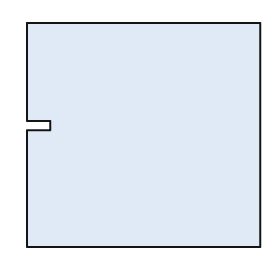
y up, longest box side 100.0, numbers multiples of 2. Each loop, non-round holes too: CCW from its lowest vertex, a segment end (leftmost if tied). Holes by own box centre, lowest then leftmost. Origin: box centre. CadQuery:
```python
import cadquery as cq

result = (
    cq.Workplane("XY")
    .moveTo(-50.0, -48.0)
    .lineTo(50.0, -48.0)
    .lineTo(50.0, 48.0)
    .lineTo(-50.0, 48.0)
    .lineTo(-50.0, 6.0)
    .lineTo(-40.0, 6.0)
    .lineTo(-40.0, 2.0)
    .lineTo(-50.0, 2.0)
    .close()
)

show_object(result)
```